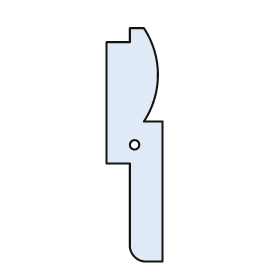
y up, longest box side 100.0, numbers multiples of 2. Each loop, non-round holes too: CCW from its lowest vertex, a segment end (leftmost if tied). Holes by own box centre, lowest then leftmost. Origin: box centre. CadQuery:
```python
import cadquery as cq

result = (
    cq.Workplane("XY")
    .moveTo(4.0, -50.0)
    .lineTo(12.0, -50.0)
    .lineTo(12.0, 10.0)
    .lineTo(4.0, 10.0)
    .threePointArc((10.0, 30.0), (4.0, 50.0))
    .lineTo(-2.0, 50.0)
    .lineTo(-2.0, 44.0)
    .lineTo(-12.0, 44.0)
    .lineTo(-12.0, -8.0)
    .lineTo(-2.0, -8.0)
    .lineTo(-2.0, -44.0)
    .threePointArc((0.0, -48.0), (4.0, -50.0))
    .close()
    .moveTo(0.0, 0.0)
    .circle(2.0)
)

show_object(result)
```